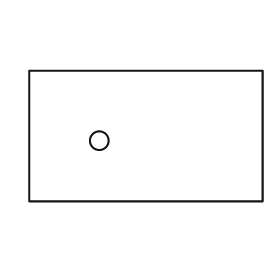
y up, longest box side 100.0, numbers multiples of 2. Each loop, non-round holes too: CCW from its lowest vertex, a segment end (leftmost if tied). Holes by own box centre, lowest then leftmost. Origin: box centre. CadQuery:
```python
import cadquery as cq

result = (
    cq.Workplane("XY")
    .moveTo(-50.0, -28.0)
    .lineTo(50.0, -28.0)
    .lineTo(50.0, 28.0)
    .lineTo(-50.0, 28.0)
    .close()
    .moveTo(-20.0, -2.0)
    .circle(4.0)
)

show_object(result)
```